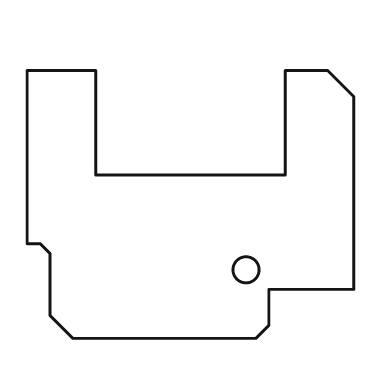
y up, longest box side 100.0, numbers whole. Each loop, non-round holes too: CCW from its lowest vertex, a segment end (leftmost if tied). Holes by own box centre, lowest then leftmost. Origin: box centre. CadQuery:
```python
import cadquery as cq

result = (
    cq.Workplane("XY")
    .moveTo(-36.0, -41.0)
    .lineTo(20.0, -41.0)
    .lineTo(24.0, -37.0)
    .lineTo(24.0, -26.0)
    .lineTo(50.0, -26.0)
    .lineTo(50.0, 33.0)
    .lineTo(42.0, 41.0)
    .lineTo(29.0, 41.0)
    .lineTo(29.0, 9.0)
    .lineTo(-29.0, 9.0)
    .lineTo(-29.0, 41.0)
    .lineTo(-50.0, 41.0)
    .lineTo(-50.0, -12.0)
    .lineTo(-46.0, -12.0)
    .lineTo(-43.0, -15.0)
    .lineTo(-43.0, -34.0)
    .close()
    .moveTo(17.0, -20.0)
    .circle(4.0)
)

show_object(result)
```